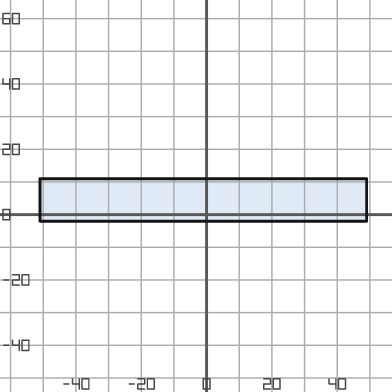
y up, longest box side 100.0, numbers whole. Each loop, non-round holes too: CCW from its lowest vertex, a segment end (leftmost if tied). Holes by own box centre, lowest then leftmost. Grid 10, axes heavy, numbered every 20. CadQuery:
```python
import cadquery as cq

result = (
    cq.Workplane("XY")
    .moveTo(-51.0, -2.0)
    .lineTo(49.0, -2.0)
    .lineTo(49.0, 11.0)
    .lineTo(-51.0, 11.0)
    .close()
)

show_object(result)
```